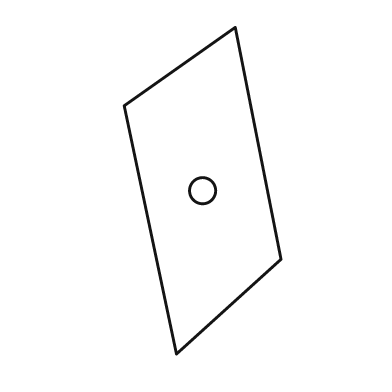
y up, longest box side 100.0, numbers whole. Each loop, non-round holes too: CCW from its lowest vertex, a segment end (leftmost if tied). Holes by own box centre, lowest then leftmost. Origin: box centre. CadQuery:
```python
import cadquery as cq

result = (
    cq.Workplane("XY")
    .moveTo(-8.0, -50.0)
    .lineTo(24.0, -21.0)
    .lineTo(10.0, 50.0)
    .lineTo(-24.0, 26.0)
    .close()
    .moveTo(0.0, 0.0)
    .circle(4.0)
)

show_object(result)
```